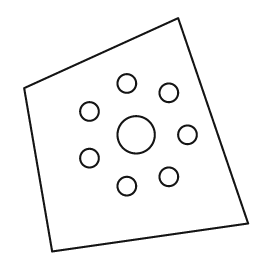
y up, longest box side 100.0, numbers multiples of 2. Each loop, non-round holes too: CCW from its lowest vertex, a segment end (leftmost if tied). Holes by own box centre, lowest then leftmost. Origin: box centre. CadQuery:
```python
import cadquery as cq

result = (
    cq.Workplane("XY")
    .moveTo(-36.0, -50.0)
    .lineTo(48.0, -38.0)
    .lineTo(18.0, 50.0)
    .lineTo(-48.0, 20.0)
    .close()
    .moveTo(-4.0, -22.0)
    .circle(4.0)
    .moveTo(14.0, -18.0)
    .circle(4.0)
    .moveTo(-20.0, -10.0)
    .circle(4.0)
    .moveTo(0.0, 0.0)
    .circle(8.0)
    .moveTo(22.0, 0.0)
    .circle(4.0)
    .moveTo(-20.0, 10.0)
    .circle(4.0)
    .moveTo(14.0, 18.0)
    .circle(4.0)
    .moveTo(-4.0, 22.0)
    .circle(4.0)
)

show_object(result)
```